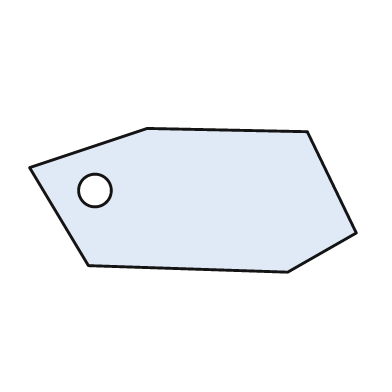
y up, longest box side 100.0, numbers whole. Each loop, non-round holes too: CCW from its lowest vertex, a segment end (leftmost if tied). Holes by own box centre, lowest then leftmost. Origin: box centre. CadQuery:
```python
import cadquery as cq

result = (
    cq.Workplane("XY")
    .moveTo(29.0, -22.0)
    .lineTo(50.0, -10.0)
    .lineTo(35.0, 21.0)
    .lineTo(-14.0, 22.0)
    .lineTo(-50.0, 10.0)
    .lineTo(-32.0, -20.0)
    .close()
    .moveTo(-30.0, 3.0)
    .circle(5.0)
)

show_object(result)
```